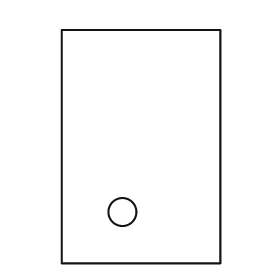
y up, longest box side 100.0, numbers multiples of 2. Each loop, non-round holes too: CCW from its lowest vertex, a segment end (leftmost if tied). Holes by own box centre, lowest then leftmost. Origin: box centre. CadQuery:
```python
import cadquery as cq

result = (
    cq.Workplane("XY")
    .moveTo(-34.0, -50.0)
    .lineTo(34.0, -50.0)
    .lineTo(34.0, 50.0)
    .lineTo(-34.0, 50.0)
    .close()
    .moveTo(-8.0, -28.0)
    .circle(6.0)
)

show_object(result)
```